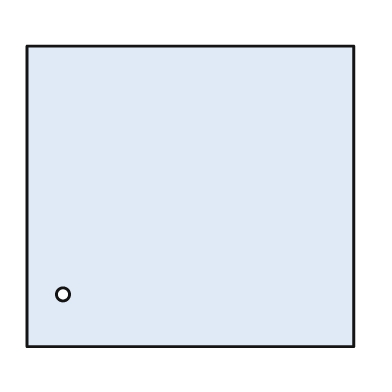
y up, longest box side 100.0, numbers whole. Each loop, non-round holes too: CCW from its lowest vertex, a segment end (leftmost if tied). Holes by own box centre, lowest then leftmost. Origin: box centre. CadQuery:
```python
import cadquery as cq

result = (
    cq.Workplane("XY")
    .moveTo(-50.0, -46.0)
    .lineTo(50.0, -46.0)
    .lineTo(50.0, 46.0)
    .lineTo(-50.0, 46.0)
    .close()
    .moveTo(-39.0, -30.0)
    .circle(2.0)
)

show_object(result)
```